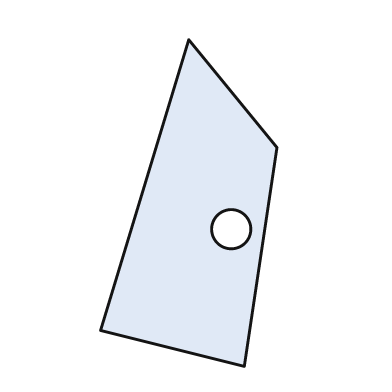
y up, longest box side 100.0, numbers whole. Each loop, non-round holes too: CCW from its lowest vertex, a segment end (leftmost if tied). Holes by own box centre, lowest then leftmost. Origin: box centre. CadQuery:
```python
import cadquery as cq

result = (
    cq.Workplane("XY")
    .moveTo(17.0, -50.0)
    .lineTo(27.0, 17.0)
    .lineTo(0.0, 50.0)
    .lineTo(-27.0, -39.0)
    .close()
    .moveTo(13.0, -8.0)
    .circle(6.0)
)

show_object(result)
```